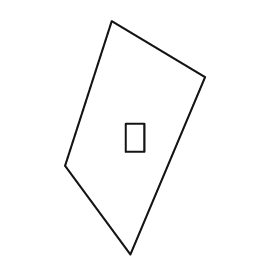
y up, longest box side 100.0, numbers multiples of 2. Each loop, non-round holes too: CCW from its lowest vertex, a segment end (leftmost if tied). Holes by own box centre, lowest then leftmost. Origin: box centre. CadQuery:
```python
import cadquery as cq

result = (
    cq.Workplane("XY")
    .moveTo(-2.0, -50.0)
    .lineTo(30.0, 26.0)
    .lineTo(-10.0, 50.0)
    .lineTo(-30.0, -12.0)
    .close()
    .moveTo(-4.0, -6.0)
    .lineTo(4.0, -6.0)
    .lineTo(4.0, 6.0)
    .lineTo(-4.0, 6.0)
    .close()
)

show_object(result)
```